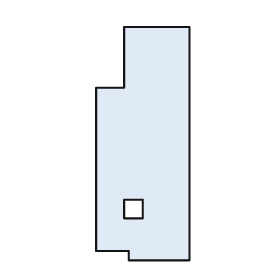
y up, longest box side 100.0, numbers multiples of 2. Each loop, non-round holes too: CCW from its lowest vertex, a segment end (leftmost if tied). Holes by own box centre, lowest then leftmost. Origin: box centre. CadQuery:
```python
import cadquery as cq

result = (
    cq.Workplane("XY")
    .moveTo(-6.0, -50.0)
    .lineTo(20.0, -50.0)
    .lineTo(20.0, 50.0)
    .lineTo(-8.0, 50.0)
    .lineTo(-8.0, 24.0)
    .lineTo(-20.0, 24.0)
    .lineTo(-20.0, -46.0)
    .lineTo(-6.0, -46.0)
    .close()
    .moveTo(-8.0, -32.0)
    .lineTo(0.0, -32.0)
    .lineTo(0.0, -24.0)
    .lineTo(-8.0, -24.0)
    .close()
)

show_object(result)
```